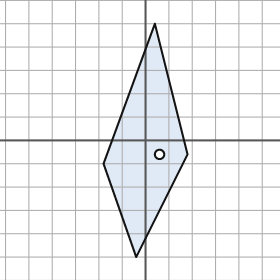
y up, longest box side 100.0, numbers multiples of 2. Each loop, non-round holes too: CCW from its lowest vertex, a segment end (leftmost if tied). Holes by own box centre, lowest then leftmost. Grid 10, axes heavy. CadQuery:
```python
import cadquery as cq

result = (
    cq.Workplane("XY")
    .moveTo(-4.0, -50.0)
    .lineTo(18.0, -6.0)
    .lineTo(4.0, 50.0)
    .lineTo(-18.0, -10.0)
    .close()
    .moveTo(6.0, -6.0)
    .circle(2.0)
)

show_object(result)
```